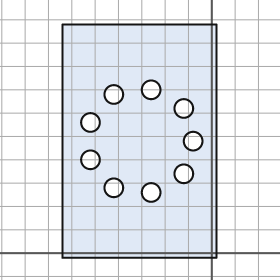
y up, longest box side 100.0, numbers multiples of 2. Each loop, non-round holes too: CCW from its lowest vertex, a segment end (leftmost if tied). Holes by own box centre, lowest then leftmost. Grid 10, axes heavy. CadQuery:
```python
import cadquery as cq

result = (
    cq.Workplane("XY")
    .moveTo(-64.0, -2.0)
    .lineTo(2.0, -2.0)
    .lineTo(2.0, 98.0)
    .lineTo(-64.0, 98.0)
    .close()
    .moveTo(-26.0, 26.0)
    .circle(4.0)
    .moveTo(-42.0, 28.0)
    .circle(4.0)
    .moveTo(-12.0, 34.0)
    .circle(4.0)
    .moveTo(-52.0, 40.0)
    .circle(4.0)
    .moveTo(-8.0, 48.0)
    .circle(4.0)
    .moveTo(-52.0, 56.0)
    .circle(4.0)
    .moveTo(-12.0, 62.0)
    .circle(4.0)
    .moveTo(-42.0, 68.0)
    .circle(4.0)
    .moveTo(-26.0, 70.0)
    .circle(4.0)
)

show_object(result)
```